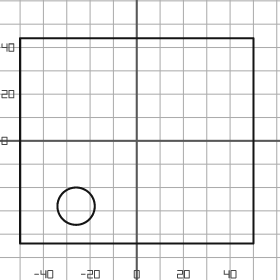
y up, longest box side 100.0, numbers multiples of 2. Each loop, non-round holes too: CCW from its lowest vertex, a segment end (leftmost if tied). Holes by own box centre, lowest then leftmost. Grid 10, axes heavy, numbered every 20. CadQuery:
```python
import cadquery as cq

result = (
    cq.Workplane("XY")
    .moveTo(-50.0, -44.0)
    .lineTo(50.0, -44.0)
    .lineTo(50.0, 44.0)
    .lineTo(-50.0, 44.0)
    .close()
    .moveTo(-26.0, -28.0)
    .circle(8.0)
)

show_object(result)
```